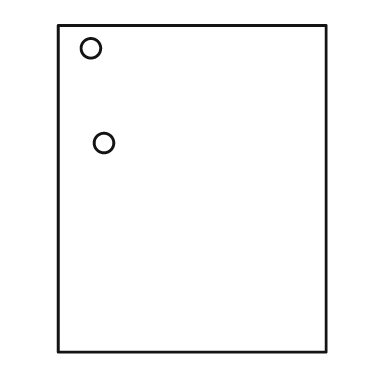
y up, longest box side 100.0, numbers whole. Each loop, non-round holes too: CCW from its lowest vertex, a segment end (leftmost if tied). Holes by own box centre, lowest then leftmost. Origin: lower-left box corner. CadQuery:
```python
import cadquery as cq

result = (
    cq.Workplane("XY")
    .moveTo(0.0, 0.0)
    .lineTo(82.0, 0.0)
    .lineTo(82.0, 100.0)
    .lineTo(0.0, 100.0)
    .close()
    .moveTo(14.0, 64.0)
    .circle(3.0)
    .moveTo(10.0, 93.0)
    .circle(3.0)
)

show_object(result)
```